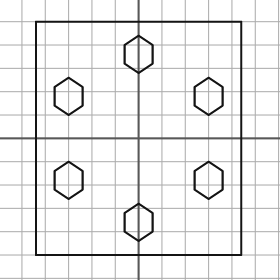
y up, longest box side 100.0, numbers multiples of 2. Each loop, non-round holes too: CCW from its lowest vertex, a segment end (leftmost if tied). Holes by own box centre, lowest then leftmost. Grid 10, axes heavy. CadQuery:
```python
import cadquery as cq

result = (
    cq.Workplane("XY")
    .moveTo(-44.0, -50.0)
    .lineTo(44.0, -50.0)
    .lineTo(44.0, 50.0)
    .lineTo(-44.0, 50.0)
    .close()
    .moveTo(0.0, -44.0)
    .lineTo(6.0, -40.0)
    .lineTo(6.0, -32.0)
    .lineTo(0.0, -28.0)
    .lineTo(-6.0, -32.0)
    .lineTo(-6.0, -40.0)
    .close()
    .moveTo(-30.0, -26.0)
    .lineTo(-24.0, -22.0)
    .lineTo(-24.0, -14.0)
    .lineTo(-30.0, -10.0)
    .lineTo(-36.0, -14.0)
    .lineTo(-36.0, -22.0)
    .close()
    .moveTo(30.0, -26.0)
    .lineTo(36.0, -22.0)
    .lineTo(36.0, -14.0)
    .lineTo(30.0, -10.0)
    .lineTo(24.0, -14.0)
    .lineTo(24.0, -22.0)
    .close()
    .moveTo(-30.0, 10.0)
    .lineTo(-24.0, 14.0)
    .lineTo(-24.0, 22.0)
    .lineTo(-30.0, 26.0)
    .lineTo(-36.0, 22.0)
    .lineTo(-36.0, 14.0)
    .close()
    .moveTo(30.0, 10.0)
    .lineTo(36.0, 14.0)
    .lineTo(36.0, 22.0)
    .lineTo(30.0, 26.0)
    .lineTo(24.0, 22.0)
    .lineTo(24.0, 14.0)
    .close()
    .moveTo(0.0, 28.0)
    .lineTo(6.0, 32.0)
    .lineTo(6.0, 40.0)
    .lineTo(0.0, 44.0)
    .lineTo(-6.0, 40.0)
    .lineTo(-6.0, 32.0)
    .close()
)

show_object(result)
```